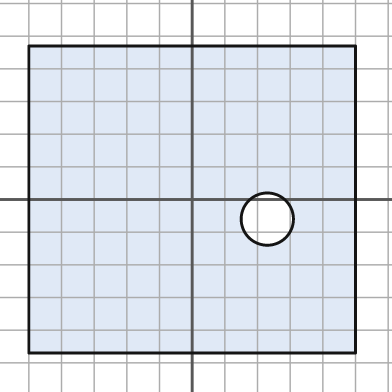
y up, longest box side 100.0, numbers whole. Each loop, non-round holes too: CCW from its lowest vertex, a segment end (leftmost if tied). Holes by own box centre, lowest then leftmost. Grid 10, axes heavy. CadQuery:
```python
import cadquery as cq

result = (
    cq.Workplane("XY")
    .moveTo(-50.0, -47.0)
    .lineTo(50.0, -47.0)
    .lineTo(50.0, 47.0)
    .lineTo(-50.0, 47.0)
    .close()
    .moveTo(23.0, -6.0)
    .circle(8.0)
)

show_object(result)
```